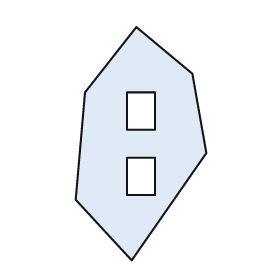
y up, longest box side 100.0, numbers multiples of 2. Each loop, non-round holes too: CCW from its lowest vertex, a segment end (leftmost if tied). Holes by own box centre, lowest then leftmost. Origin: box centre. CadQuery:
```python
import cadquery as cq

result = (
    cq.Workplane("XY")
    .moveTo(-4.0, -50.0)
    .lineTo(28.0, -4.0)
    .lineTo(22.0, 30.0)
    .lineTo(-2.0, 50.0)
    .lineTo(-24.0, 22.0)
    .lineTo(-28.0, -24.0)
    .close()
    .moveTo(-6.0, -22.0)
    .lineTo(6.0, -22.0)
    .lineTo(6.0, -6.0)
    .lineTo(-6.0, -6.0)
    .close()
    .moveTo(-6.0, 6.0)
    .lineTo(6.0, 6.0)
    .lineTo(6.0, 22.0)
    .lineTo(-6.0, 22.0)
    .close()
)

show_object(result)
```